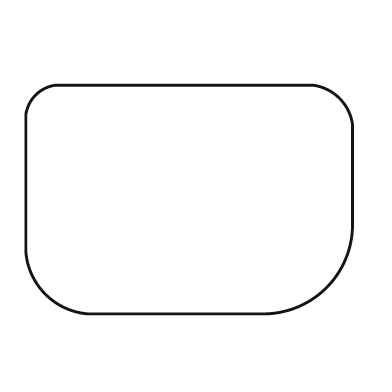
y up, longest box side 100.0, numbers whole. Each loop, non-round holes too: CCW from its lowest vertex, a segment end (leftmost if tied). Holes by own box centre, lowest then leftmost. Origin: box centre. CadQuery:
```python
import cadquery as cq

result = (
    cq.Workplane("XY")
    .moveTo(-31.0, -35.0)
    .lineTo(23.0, -35.0)
    .threePointArc((42.0, -27.0), (50.0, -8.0))
    .lineTo(50.0, 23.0)
    .threePointArc((46.0, 31.0), (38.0, 35.0))
    .lineTo(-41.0, 35.0)
    .threePointArc((-47.0, 32.0), (-50.0, 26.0))
    .lineTo(-50.0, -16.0)
    .threePointArc((-44.0, -29.0), (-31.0, -35.0))
    .close()
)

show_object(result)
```